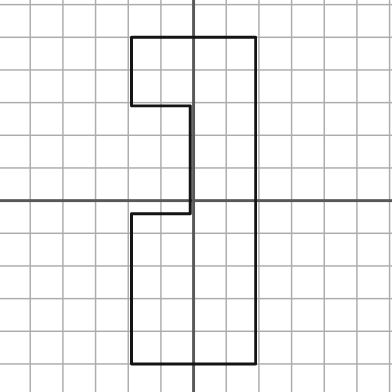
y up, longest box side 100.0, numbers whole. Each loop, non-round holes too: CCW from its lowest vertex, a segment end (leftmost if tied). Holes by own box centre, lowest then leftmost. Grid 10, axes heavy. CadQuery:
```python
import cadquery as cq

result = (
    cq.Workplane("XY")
    .moveTo(-19.0, -50.0)
    .lineTo(19.0, -50.0)
    .lineTo(19.0, 50.0)
    .lineTo(-19.0, 50.0)
    .lineTo(-19.0, 29.0)
    .lineTo(-1.0, 29.0)
    .lineTo(-1.0, -4.0)
    .lineTo(-19.0, -4.0)
    .close()
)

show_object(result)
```